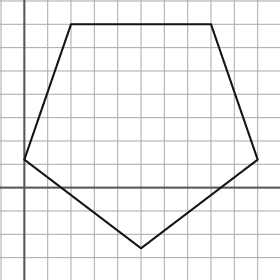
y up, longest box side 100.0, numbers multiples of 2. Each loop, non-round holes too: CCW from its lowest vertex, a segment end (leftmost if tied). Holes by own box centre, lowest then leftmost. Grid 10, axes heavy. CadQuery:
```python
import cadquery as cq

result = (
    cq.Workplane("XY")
    .moveTo(50.0, -26.0)
    .lineTo(100.0, 12.0)
    .lineTo(80.0, 70.0)
    .lineTo(20.0, 70.0)
    .lineTo(0.0, 12.0)
    .close()
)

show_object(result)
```